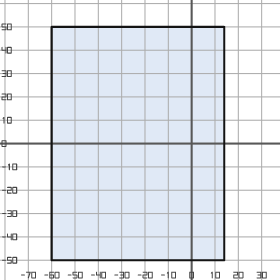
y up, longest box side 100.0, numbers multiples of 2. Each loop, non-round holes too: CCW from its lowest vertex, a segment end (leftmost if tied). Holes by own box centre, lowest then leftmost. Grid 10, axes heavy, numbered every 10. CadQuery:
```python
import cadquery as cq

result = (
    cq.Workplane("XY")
    .moveTo(-60.0, -50.0)
    .lineTo(14.0, -50.0)
    .lineTo(14.0, 50.0)
    .lineTo(-60.0, 50.0)
    .close()
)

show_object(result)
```